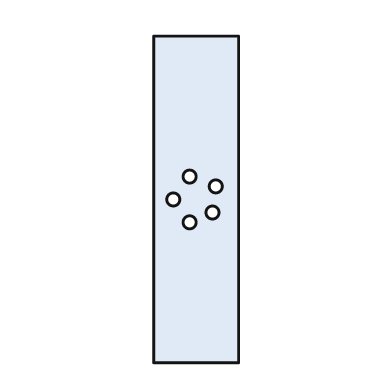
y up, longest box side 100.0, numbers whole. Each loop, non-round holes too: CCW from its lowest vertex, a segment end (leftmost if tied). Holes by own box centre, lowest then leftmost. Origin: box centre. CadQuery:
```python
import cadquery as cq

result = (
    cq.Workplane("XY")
    .moveTo(-13.0, -50.0)
    .lineTo(13.0, -50.0)
    .lineTo(13.0, 50.0)
    .lineTo(-13.0, 50.0)
    .close()
    .moveTo(-2.0, -7.0)
    .circle(2.0)
    .moveTo(5.0, -4.0)
    .circle(2.0)
    .moveTo(-7.0, 0.0)
    .circle(2.0)
    .moveTo(6.0, 4.0)
    .circle(2.0)
    .moveTo(-2.0, 7.0)
    .circle(2.0)
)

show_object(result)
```